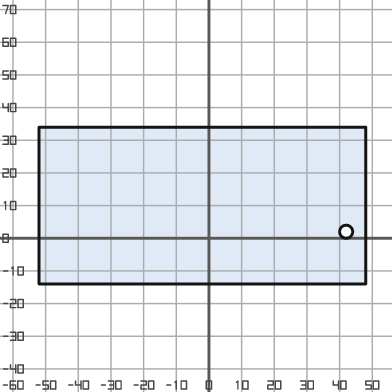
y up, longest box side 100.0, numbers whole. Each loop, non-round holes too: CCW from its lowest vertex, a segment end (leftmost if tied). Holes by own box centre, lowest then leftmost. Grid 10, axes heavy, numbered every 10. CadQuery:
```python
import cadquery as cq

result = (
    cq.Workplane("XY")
    .moveTo(-52.0, -14.0)
    .lineTo(48.0, -14.0)
    .lineTo(48.0, 34.0)
    .lineTo(-52.0, 34.0)
    .close()
    .moveTo(42.0, 2.0)
    .circle(2.0)
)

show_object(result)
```